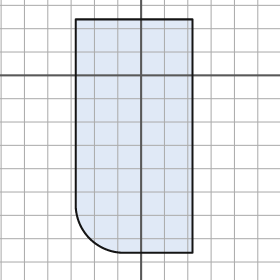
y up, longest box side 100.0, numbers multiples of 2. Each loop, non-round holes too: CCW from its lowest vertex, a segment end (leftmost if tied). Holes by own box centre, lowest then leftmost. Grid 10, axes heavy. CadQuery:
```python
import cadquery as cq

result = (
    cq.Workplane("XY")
    .moveTo(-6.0, -76.0)
    .lineTo(22.0, -76.0)
    .lineTo(22.0, 24.0)
    .lineTo(-28.0, 24.0)
    .lineTo(-28.0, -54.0)
    .threePointArc((-22.0, -70.0), (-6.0, -76.0))
    .close()
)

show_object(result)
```